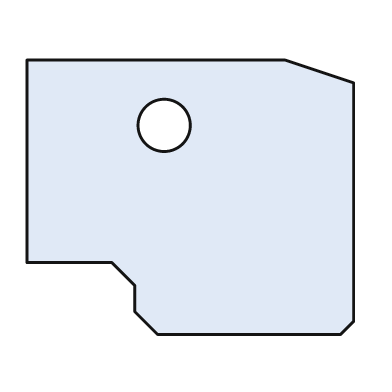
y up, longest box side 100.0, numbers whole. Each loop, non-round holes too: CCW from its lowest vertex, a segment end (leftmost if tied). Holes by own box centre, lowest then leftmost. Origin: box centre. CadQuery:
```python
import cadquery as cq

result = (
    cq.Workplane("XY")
    .moveTo(-10.0, -42.0)
    .lineTo(46.0, -42.0)
    .lineTo(50.0, -38.0)
    .lineTo(50.0, 35.0)
    .lineTo(29.0, 42.0)
    .lineTo(-50.0, 42.0)
    .lineTo(-50.0, -20.0)
    .lineTo(-24.0, -20.0)
    .lineTo(-17.0, -27.0)
    .lineTo(-17.0, -35.0)
    .close()
    .moveTo(-8.0, 22.0)
    .circle(8.0)
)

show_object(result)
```